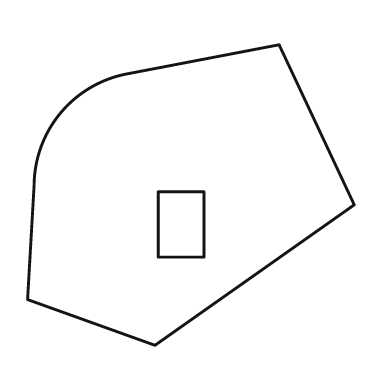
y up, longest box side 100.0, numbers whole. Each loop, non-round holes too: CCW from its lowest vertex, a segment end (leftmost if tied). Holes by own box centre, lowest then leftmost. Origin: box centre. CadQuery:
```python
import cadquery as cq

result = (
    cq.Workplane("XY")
    .moveTo(-11.0, -46.0)
    .lineTo(50.0, -3.0)
    .lineTo(27.0, 46.0)
    .lineTo(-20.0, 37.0)
    .threePointArc((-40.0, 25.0), (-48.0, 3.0))
    .lineTo(-50.0, -32.0)
    .close()
    .moveTo(-10.0, -19.0)
    .lineTo(4.0, -19.0)
    .lineTo(4.0, 1.0)
    .lineTo(-10.0, 1.0)
    .close()
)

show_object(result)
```